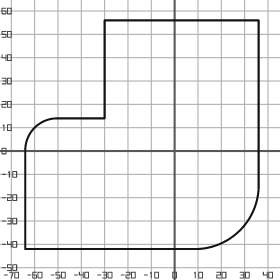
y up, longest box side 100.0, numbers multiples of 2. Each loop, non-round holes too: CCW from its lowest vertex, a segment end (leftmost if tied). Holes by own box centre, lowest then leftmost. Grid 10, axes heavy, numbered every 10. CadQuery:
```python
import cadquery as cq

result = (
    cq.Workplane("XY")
    .moveTo(-64.0, -42.0)
    .lineTo(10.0, -42.0)
    .threePointArc((28.0, -34.0), (36.0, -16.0))
    .lineTo(36.0, 56.0)
    .lineTo(-30.0, 56.0)
    .lineTo(-30.0, 14.0)
    .lineTo(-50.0, 14.0)
    .threePointArc((-60.0, 10.0), (-64.0, 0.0))
    .close()
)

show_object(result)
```